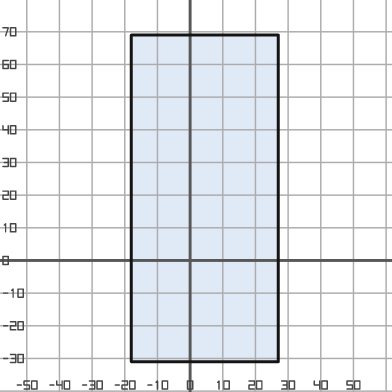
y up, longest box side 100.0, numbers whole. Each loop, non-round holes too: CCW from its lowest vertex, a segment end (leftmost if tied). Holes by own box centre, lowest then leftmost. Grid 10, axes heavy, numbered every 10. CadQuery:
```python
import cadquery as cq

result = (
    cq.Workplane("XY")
    .moveTo(-18.0, -31.0)
    .lineTo(27.0, -31.0)
    .lineTo(27.0, 69.0)
    .lineTo(-18.0, 69.0)
    .close()
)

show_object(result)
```